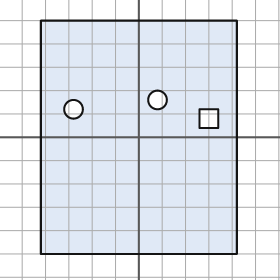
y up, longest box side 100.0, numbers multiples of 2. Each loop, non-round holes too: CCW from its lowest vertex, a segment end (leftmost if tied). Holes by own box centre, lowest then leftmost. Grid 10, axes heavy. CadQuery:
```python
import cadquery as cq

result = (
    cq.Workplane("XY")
    .moveTo(-42.0, -50.0)
    .lineTo(42.0, -50.0)
    .lineTo(42.0, 50.0)
    .lineTo(-42.0, 50.0)
    .close()
    .moveTo(26.0, 4.0)
    .lineTo(34.0, 4.0)
    .lineTo(34.0, 12.0)
    .lineTo(26.0, 12.0)
    .close()
    .moveTo(-28.0, 12.0)
    .circle(4.0)
    .moveTo(8.0, 16.0)
    .circle(4.0)
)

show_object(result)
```